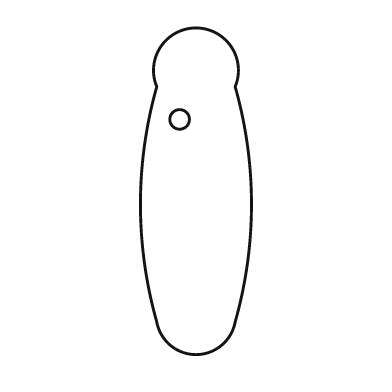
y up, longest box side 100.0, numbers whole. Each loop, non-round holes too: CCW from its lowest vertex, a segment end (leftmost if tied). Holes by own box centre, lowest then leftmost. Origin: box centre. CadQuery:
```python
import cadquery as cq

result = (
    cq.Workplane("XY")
    .moveTo(-12.0, -40.0)
    .threePointArc((0.0, -50.0), (12.0, -40.0))
    .threePointArc((17.0, -4.0), (12.0, 32.0))
    .threePointArc((0.0, 50.0), (-12.0, 32.0))
    .threePointArc((-17.0, -4.0), (-12.0, -40.0))
    .close()
    .moveTo(-5.0, 22.0)
    .circle(3.0)
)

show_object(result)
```